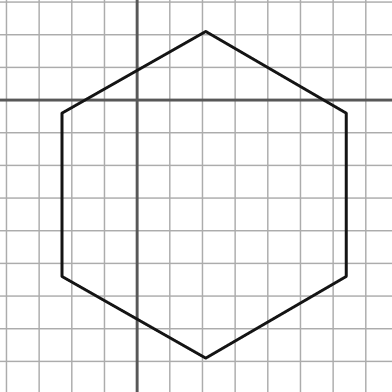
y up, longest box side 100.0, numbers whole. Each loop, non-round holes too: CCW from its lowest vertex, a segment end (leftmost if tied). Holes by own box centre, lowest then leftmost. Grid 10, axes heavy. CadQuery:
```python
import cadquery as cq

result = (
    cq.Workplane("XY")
    .moveTo(21.0, -79.0)
    .lineTo(64.0, -54.0)
    .lineTo(64.0, -4.0)
    .lineTo(21.0, 21.0)
    .lineTo(-23.0, -4.0)
    .lineTo(-23.0, -54.0)
    .close()
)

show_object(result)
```